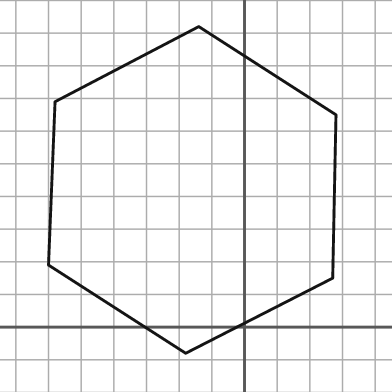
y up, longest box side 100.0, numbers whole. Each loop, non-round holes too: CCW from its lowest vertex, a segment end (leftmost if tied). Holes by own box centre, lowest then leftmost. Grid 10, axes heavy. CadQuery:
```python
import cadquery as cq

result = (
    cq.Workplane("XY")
    .moveTo(-18.0, -8.0)
    .lineTo(27.0, 15.0)
    .lineTo(28.0, 65.0)
    .lineTo(-14.0, 92.0)
    .lineTo(-58.0, 69.0)
    .lineTo(-60.0, 19.0)
    .close()
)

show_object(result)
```